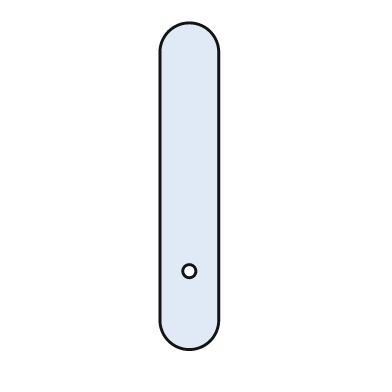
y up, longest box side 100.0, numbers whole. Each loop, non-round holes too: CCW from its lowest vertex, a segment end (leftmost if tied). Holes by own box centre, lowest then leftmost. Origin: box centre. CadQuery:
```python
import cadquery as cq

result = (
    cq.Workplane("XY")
    .moveTo(-9.0, -41.0)
    .threePointArc((0.0, -50.0), (9.0, -41.0))
    .lineTo(9.0, 41.0)
    .threePointArc((0.0, 50.0), (-9.0, 41.0))
    .close()
    .moveTo(0.0, -26.0)
    .circle(2.0)
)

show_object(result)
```